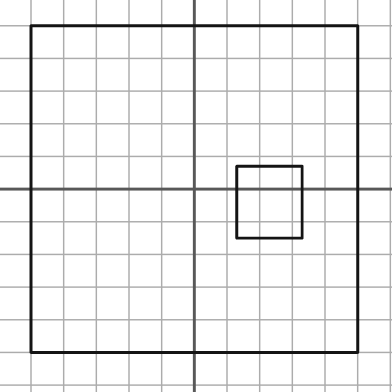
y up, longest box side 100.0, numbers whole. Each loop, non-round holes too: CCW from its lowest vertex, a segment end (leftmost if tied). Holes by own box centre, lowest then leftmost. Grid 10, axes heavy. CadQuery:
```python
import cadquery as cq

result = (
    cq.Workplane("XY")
    .moveTo(-50.0, -50.0)
    .lineTo(50.0, -50.0)
    .lineTo(50.0, 50.0)
    .lineTo(-50.0, 50.0)
    .close()
    .moveTo(13.0, -15.0)
    .lineTo(33.0, -15.0)
    .lineTo(33.0, 7.0)
    .lineTo(13.0, 7.0)
    .close()
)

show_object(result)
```